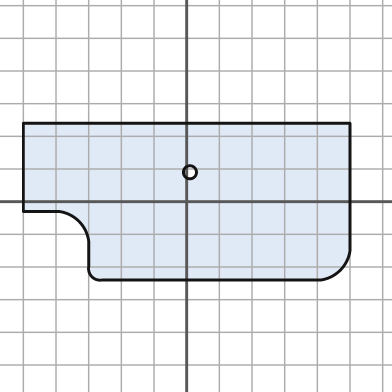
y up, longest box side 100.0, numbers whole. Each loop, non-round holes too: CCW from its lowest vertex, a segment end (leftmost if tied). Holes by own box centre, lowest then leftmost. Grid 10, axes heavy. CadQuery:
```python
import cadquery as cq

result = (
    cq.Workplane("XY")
    .moveTo(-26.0, -24.0)
    .lineTo(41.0, -24.0)
    .threePointArc((47.0, -21.0), (50.0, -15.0))
    .lineTo(50.0, 24.0)
    .lineTo(-50.0, 24.0)
    .lineTo(-50.0, -3.0)
    .lineTo(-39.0, -3.0)
    .threePointArc((-33.0, -6.0), (-30.0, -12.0))
    .lineTo(-30.0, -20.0)
    .threePointArc((-29.0, -23.0), (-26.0, -24.0))
    .close()
    .moveTo(1.0, 9.0)
    .circle(2.0)
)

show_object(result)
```